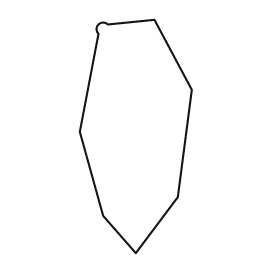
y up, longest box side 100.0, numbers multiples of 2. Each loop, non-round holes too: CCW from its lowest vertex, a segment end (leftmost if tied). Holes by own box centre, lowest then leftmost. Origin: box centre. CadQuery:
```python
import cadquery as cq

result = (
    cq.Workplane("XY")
    .moveTo(0.0, -50.0)
    .lineTo(18.0, -26.0)
    .lineTo(24.0, 20.0)
    .lineTo(8.0, 50.0)
    .lineTo(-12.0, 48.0)
    .threePointArc((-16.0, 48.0), (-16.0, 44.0))
    .lineTo(-24.0, 2.0)
    .lineTo(-14.0, -34.0)
    .close()
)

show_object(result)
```